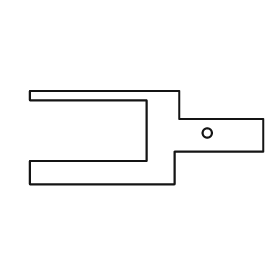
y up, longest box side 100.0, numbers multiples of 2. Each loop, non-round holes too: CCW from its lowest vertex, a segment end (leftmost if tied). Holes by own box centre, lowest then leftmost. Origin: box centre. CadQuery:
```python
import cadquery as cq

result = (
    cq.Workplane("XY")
    .moveTo(-50.0, -20.0)
    .lineTo(12.0, -20.0)
    .lineTo(12.0, -6.0)
    .lineTo(50.0, -6.0)
    .lineTo(50.0, 8.0)
    .lineTo(14.0, 8.0)
    .lineTo(14.0, 20.0)
    .lineTo(-50.0, 20.0)
    .lineTo(-50.0, 16.0)
    .lineTo(0.0, 16.0)
    .lineTo(0.0, -10.0)
    .lineTo(-50.0, -10.0)
    .close()
    .moveTo(26.0, 2.0)
    .circle(2.0)
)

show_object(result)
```